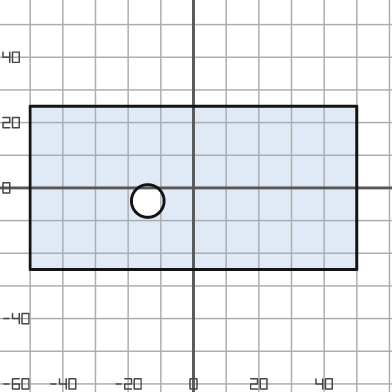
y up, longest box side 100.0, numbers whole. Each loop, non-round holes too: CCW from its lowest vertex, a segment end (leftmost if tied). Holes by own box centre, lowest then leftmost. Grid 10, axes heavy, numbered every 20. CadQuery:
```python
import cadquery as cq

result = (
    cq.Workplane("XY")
    .moveTo(-50.0, -25.0)
    .lineTo(50.0, -25.0)
    .lineTo(50.0, 25.0)
    .lineTo(-50.0, 25.0)
    .close()
    .moveTo(-14.0, -4.0)
    .circle(5.0)
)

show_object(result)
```